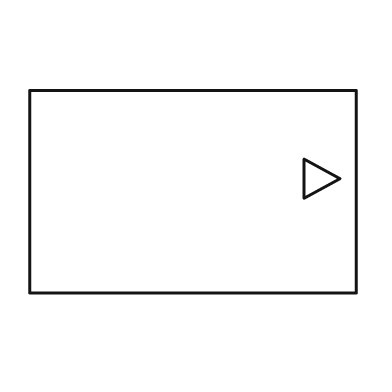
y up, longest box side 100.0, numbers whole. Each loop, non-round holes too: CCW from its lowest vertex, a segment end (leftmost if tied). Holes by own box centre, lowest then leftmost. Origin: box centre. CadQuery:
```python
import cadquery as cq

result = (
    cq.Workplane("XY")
    .moveTo(-50.0, -31.0)
    .lineTo(50.0, -31.0)
    .lineTo(50.0, 31.0)
    .lineTo(-50.0, 31.0)
    .close()
    .moveTo(34.0, -2.0)
    .lineTo(45.0, 4.0)
    .lineTo(34.0, 10.0)
    .close()
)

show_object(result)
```